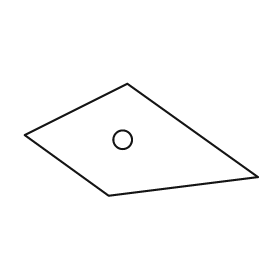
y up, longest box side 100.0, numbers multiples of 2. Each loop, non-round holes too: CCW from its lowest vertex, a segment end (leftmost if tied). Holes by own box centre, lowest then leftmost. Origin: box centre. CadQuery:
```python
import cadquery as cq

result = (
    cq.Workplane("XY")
    .moveTo(-14.0, -24.0)
    .lineTo(50.0, -16.0)
    .lineTo(-6.0, 24.0)
    .lineTo(-50.0, 2.0)
    .close()
    .moveTo(-8.0, 0.0)
    .circle(4.0)
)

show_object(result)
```